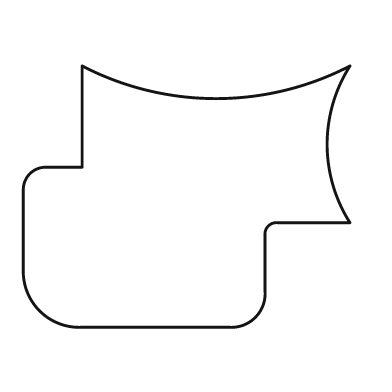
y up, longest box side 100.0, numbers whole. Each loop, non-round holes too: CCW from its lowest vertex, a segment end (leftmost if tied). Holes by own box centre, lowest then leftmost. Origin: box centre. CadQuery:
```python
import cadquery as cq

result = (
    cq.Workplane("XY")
    .moveTo(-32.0, -40.0)
    .lineTo(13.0, -40.0)
    .threePointArc((21.0, -37.0), (24.0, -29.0))
    .lineTo(24.0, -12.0)
    .threePointArc((25.0, -9.0), (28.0, -8.0))
    .lineTo(50.0, -8.0)
    .threePointArc((43.0, 16.0), (50.0, 40.0))
    .threePointArc((9.0, 30.0), (-32.0, 40.0))
    .lineTo(-32.0, 9.0)
    .lineTo(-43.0, 9.0)
    .threePointArc((-48.0, 7.0), (-50.0, 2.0))
    .lineTo(-50.0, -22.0)
    .threePointArc((-45.0, -35.0), (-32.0, -40.0))
    .close()
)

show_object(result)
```